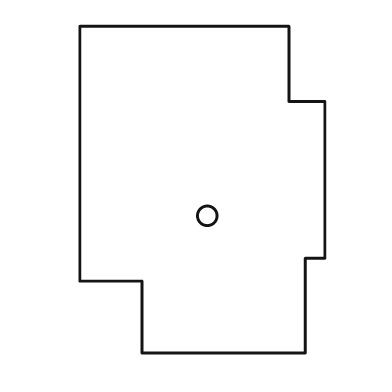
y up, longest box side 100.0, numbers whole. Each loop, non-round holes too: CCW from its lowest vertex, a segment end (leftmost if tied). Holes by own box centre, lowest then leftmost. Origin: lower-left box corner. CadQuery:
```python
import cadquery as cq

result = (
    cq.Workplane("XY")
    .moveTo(19.0, 0.0)
    .lineTo(69.0, 0.0)
    .lineTo(69.0, 29.0)
    .lineTo(75.0, 29.0)
    .lineTo(75.0, 77.0)
    .lineTo(64.0, 77.0)
    .lineTo(64.0, 100.0)
    .lineTo(0.0, 100.0)
    .lineTo(0.0, 22.0)
    .lineTo(19.0, 22.0)
    .close()
    .moveTo(39.0, 42.0)
    .circle(3.0)
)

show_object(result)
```